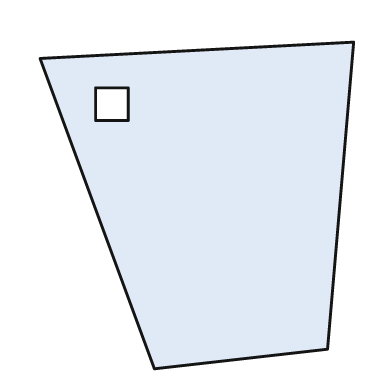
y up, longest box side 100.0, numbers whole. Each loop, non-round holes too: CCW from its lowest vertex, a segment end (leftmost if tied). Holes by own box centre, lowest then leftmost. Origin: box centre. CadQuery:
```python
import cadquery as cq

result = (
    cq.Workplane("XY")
    .moveTo(-13.0, -50.0)
    .lineTo(40.0, -44.0)
    .lineTo(48.0, 50.0)
    .lineTo(-48.0, 45.0)
    .close()
    .moveTo(-31.0, 26.0)
    .lineTo(-21.0, 26.0)
    .lineTo(-21.0, 36.0)
    .lineTo(-31.0, 36.0)
    .close()
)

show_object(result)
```